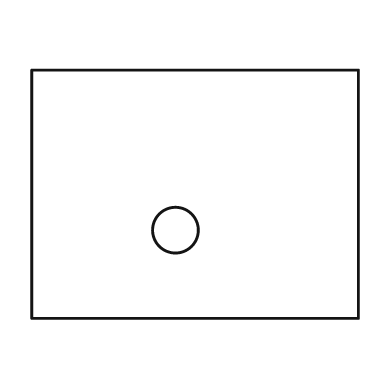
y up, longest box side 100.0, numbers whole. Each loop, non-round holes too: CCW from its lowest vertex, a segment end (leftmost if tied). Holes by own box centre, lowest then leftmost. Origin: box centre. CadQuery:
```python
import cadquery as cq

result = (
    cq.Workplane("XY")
    .moveTo(-50.0, -38.0)
    .lineTo(50.0, -38.0)
    .lineTo(50.0, 38.0)
    .lineTo(-50.0, 38.0)
    .close()
    .moveTo(-6.0, -11.0)
    .circle(7.0)
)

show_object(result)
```